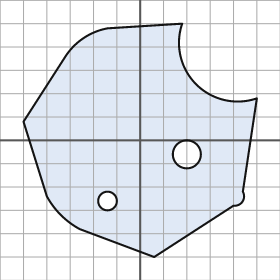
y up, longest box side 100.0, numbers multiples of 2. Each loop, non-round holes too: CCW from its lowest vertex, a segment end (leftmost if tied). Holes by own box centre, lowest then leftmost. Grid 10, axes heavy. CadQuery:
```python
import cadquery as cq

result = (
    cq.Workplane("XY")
    .moveTo(6.0, -50.0)
    .lineTo(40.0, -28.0)
    .threePointArc((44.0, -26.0), (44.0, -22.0))
    .lineTo(50.0, 18.0)
    .threePointArc((24.0, 24.0), (18.0, 50.0))
    .lineTo(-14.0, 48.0)
    .threePointArc((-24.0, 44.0), (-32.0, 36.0))
    .lineTo(-50.0, 8.0)
    .lineTo(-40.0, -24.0)
    .threePointArc((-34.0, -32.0), (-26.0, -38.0))
    .close()
    .moveTo(-14.0, -26.0)
    .circle(4.0)
    .moveTo(20.0, -6.0)
    .circle(6.0)
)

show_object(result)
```